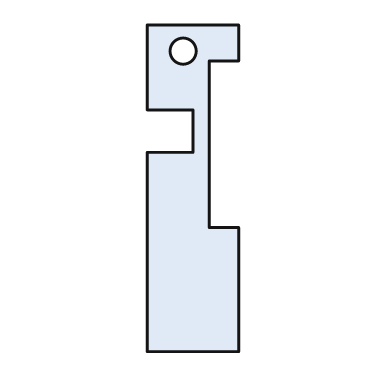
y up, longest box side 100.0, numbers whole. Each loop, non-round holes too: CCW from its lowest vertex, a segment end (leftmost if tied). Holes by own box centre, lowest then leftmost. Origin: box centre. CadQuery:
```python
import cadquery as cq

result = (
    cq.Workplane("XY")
    .moveTo(-14.0, -50.0)
    .lineTo(14.0, -50.0)
    .lineTo(14.0, -12.0)
    .lineTo(5.0, -12.0)
    .lineTo(5.0, 39.0)
    .lineTo(14.0, 39.0)
    .lineTo(14.0, 50.0)
    .lineTo(-14.0, 50.0)
    .lineTo(-14.0, 24.0)
    .lineTo(0.0, 24.0)
    .lineTo(0.0, 11.0)
    .lineTo(-14.0, 11.0)
    .close()
    .moveTo(-3.0, 42.0)
    .circle(4.0)
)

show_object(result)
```